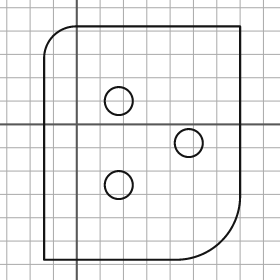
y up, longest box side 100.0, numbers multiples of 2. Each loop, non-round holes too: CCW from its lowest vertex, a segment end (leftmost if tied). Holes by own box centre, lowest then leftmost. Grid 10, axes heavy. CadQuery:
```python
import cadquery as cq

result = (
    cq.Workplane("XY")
    .moveTo(-14.0, -58.0)
    .lineTo(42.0, -58.0)
    .threePointArc((62.0, -50.0), (70.0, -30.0))
    .lineTo(70.0, 42.0)
    .lineTo(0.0, 42.0)
    .threePointArc((-10.0, 38.0), (-14.0, 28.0))
    .close()
    .moveTo(18.0, -26.0)
    .circle(6.0)
    .moveTo(48.0, -8.0)
    .circle(6.0)
    .moveTo(18.0, 10.0)
    .circle(6.0)
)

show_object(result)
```